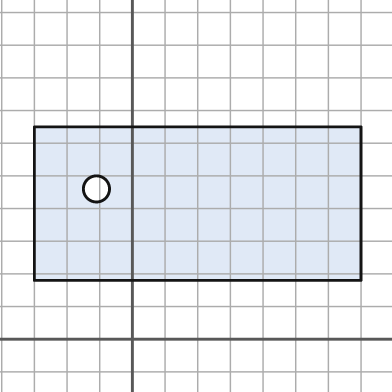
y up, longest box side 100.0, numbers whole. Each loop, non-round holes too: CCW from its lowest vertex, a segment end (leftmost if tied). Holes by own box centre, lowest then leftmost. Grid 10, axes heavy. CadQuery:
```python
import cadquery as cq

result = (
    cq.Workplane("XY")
    .moveTo(-30.0, 18.0)
    .lineTo(70.0, 18.0)
    .lineTo(70.0, 65.0)
    .lineTo(-30.0, 65.0)
    .close()
    .moveTo(-11.0, 46.0)
    .circle(4.0)
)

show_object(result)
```